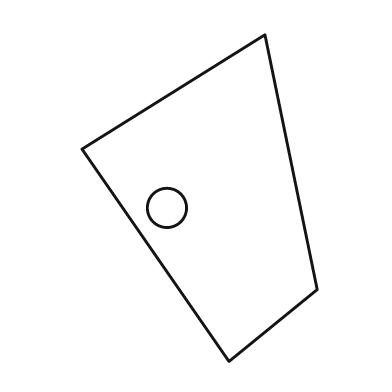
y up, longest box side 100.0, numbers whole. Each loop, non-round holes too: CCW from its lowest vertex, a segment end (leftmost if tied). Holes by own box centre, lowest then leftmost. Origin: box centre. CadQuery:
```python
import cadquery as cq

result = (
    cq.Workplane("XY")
    .moveTo(9.0, -50.0)
    .lineTo(36.0, -28.0)
    .lineTo(20.0, 50.0)
    .lineTo(-36.0, 15.0)
    .close()
    .moveTo(-10.0, -3.0)
    .circle(6.0)
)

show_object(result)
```